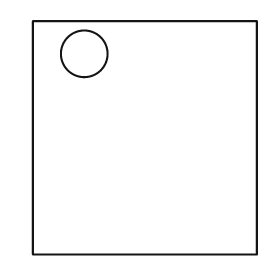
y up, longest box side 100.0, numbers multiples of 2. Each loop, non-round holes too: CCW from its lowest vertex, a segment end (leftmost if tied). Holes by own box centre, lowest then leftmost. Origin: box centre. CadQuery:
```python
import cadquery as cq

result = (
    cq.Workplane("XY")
    .moveTo(-48.0, -50.0)
    .lineTo(48.0, -50.0)
    .lineTo(48.0, 50.0)
    .lineTo(-48.0, 50.0)
    .close()
    .moveTo(-26.0, 36.0)
    .circle(10.0)
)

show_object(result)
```